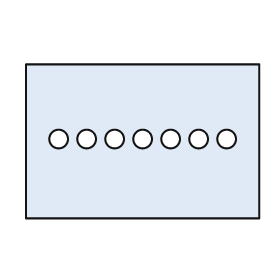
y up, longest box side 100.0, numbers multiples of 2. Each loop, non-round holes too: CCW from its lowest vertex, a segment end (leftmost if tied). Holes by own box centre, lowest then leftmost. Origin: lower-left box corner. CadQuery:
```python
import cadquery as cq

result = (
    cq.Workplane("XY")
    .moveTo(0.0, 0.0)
    .lineTo(100.0, 0.0)
    .lineTo(100.0, 66.0)
    .lineTo(0.0, 66.0)
    .close()
    .moveTo(14.0, 34.0)
    .circle(4.0)
    .moveTo(26.0, 34.0)
    .circle(4.0)
    .moveTo(38.0, 34.0)
    .circle(4.0)
    .moveTo(50.0, 34.0)
    .circle(4.0)
    .moveTo(62.0, 34.0)
    .circle(4.0)
    .moveTo(74.0, 34.0)
    .circle(4.0)
    .moveTo(86.0, 34.0)
    .circle(4.0)
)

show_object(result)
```